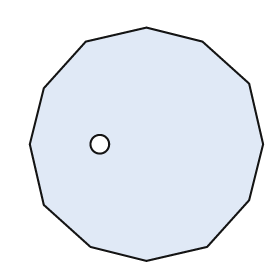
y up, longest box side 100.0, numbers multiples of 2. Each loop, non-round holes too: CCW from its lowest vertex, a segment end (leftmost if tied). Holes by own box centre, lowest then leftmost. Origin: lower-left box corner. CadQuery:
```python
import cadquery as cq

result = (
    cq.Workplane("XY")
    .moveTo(50.0, 0.0)
    .lineTo(76.0, 6.0)
    .lineTo(94.0, 26.0)
    .lineTo(100.0, 50.0)
    .lineTo(94.0, 76.0)
    .lineTo(74.0, 94.0)
    .lineTo(50.0, 100.0)
    .lineTo(24.0, 94.0)
    .lineTo(6.0, 74.0)
    .lineTo(0.0, 50.0)
    .lineTo(6.0, 24.0)
    .lineTo(26.0, 6.0)
    .close()
    .moveTo(30.0, 50.0)
    .circle(4.0)
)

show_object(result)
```